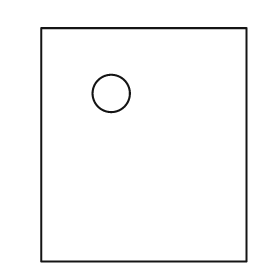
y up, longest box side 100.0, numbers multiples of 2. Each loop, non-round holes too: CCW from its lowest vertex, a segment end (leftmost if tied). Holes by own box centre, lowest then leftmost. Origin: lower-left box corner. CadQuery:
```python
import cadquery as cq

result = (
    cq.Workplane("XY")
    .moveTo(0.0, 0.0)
    .lineTo(88.0, 0.0)
    .lineTo(88.0, 100.0)
    .lineTo(0.0, 100.0)
    .close()
    .moveTo(30.0, 72.0)
    .circle(8.0)
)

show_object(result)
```